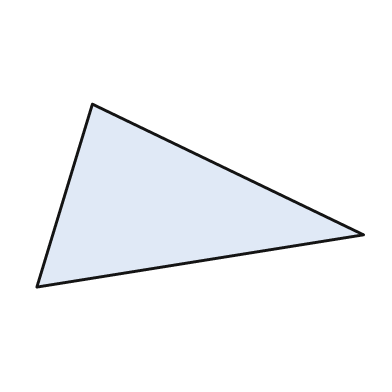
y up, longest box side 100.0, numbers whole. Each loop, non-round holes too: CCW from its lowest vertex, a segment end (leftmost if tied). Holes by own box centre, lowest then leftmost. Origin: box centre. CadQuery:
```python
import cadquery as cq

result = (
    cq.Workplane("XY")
    .moveTo(-50.0, -28.0)
    .lineTo(50.0, -12.0)
    .lineTo(-33.0, 28.0)
    .close()
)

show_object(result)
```